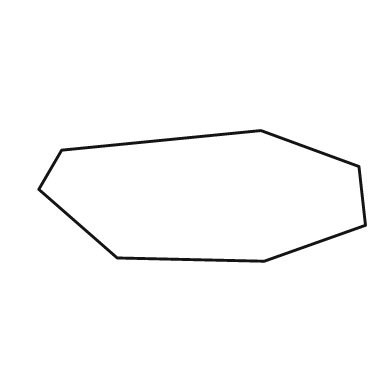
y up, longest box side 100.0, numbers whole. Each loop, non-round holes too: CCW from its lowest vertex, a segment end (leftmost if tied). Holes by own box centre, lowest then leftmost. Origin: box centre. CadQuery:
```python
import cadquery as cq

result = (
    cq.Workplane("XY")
    .moveTo(19.0, -20.0)
    .lineTo(50.0, -9.0)
    .lineTo(48.0, 9.0)
    .lineTo(18.0, 20.0)
    .lineTo(-43.0, 14.0)
    .lineTo(-50.0, 2.0)
    .lineTo(-26.0, -19.0)
    .close()
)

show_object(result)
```